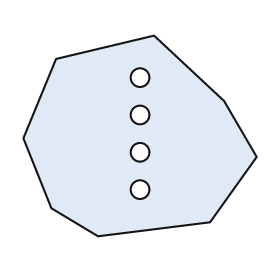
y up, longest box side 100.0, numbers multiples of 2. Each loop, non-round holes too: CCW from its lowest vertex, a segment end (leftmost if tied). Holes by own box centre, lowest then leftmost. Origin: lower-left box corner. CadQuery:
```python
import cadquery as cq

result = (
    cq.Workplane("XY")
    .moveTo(32.0, 0.0)
    .lineTo(80.0, 6.0)
    .lineTo(100.0, 34.0)
    .lineTo(86.0, 58.0)
    .lineTo(56.0, 86.0)
    .lineTo(14.0, 76.0)
    .lineTo(0.0, 42.0)
    .lineTo(12.0, 12.0)
    .close()
    .moveTo(50.0, 20.0)
    .circle(4.0)
    .moveTo(50.0, 36.0)
    .circle(4.0)
    .moveTo(50.0, 52.0)
    .circle(4.0)
    .moveTo(50.0, 68.0)
    .circle(4.0)
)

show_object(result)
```